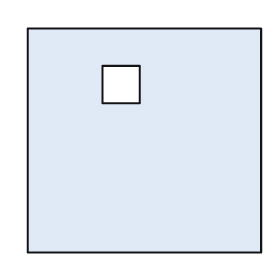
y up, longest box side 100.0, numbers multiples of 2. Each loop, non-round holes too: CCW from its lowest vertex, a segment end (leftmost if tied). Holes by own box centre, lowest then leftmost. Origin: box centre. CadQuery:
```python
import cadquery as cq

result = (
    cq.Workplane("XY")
    .moveTo(-50.0, -48.0)
    .lineTo(50.0, -48.0)
    .lineTo(50.0, 48.0)
    .lineTo(-50.0, 48.0)
    .close()
    .moveTo(-18.0, 16.0)
    .lineTo(-2.0, 16.0)
    .lineTo(-2.0, 32.0)
    .lineTo(-18.0, 32.0)
    .close()
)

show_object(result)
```